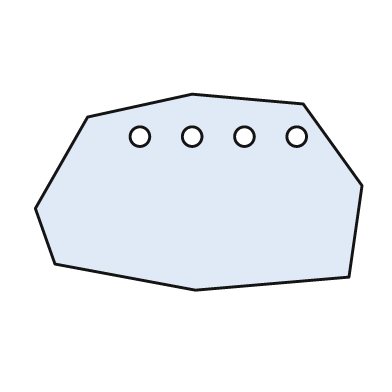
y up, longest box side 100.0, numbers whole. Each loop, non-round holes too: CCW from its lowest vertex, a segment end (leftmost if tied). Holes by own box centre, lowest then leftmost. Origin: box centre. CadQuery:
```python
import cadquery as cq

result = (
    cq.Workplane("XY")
    .moveTo(-1.0, -30.0)
    .lineTo(46.0, -26.0)
    .lineTo(50.0, 2.0)
    .lineTo(32.0, 27.0)
    .lineTo(-2.0, 30.0)
    .lineTo(-34.0, 23.0)
    .lineTo(-50.0, -5.0)
    .lineTo(-44.0, -22.0)
    .close()
    .moveTo(-18.0, 17.0)
    .circle(3.0)
    .moveTo(-2.0, 17.0)
    .circle(3.0)
    .moveTo(14.0, 17.0)
    .circle(3.0)
    .moveTo(30.0, 17.0)
    .circle(3.0)
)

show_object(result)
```